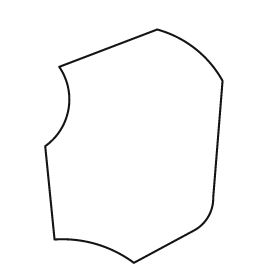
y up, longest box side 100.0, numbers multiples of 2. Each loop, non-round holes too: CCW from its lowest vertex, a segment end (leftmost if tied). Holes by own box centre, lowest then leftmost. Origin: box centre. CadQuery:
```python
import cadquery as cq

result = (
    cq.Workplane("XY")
    .moveTo(0.0, -50.0)
    .lineTo(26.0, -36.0)
    .threePointArc((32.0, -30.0), (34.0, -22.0))
    .lineTo(38.0, 28.0)
    .threePointArc((26.0, 42.0), (10.0, 50.0))
    .lineTo(-32.0, 34.0)
    .threePointArc((-28.0, 16.0), (-38.0, 0.0))
    .lineTo(-34.0, -40.0)
    .threePointArc((-16.0, -42.0), (0.0, -50.0))
    .close()
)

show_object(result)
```